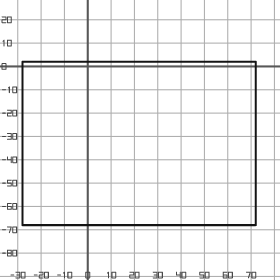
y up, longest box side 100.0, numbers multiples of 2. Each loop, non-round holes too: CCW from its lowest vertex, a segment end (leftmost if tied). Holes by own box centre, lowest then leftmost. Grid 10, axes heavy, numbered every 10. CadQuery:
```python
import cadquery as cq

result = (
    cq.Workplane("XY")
    .moveTo(-28.0, -68.0)
    .lineTo(72.0, -68.0)
    .lineTo(72.0, 2.0)
    .lineTo(-28.0, 2.0)
    .close()
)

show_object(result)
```